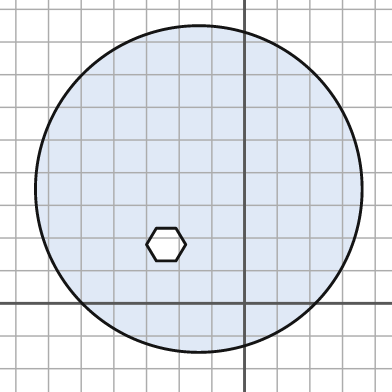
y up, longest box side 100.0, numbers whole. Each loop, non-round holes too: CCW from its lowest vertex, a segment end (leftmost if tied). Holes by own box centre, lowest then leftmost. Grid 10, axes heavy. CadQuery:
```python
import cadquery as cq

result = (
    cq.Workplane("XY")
    .moveTo(-14.0, 35.0)
    .circle(50.0)
    .moveTo(-27.0, 13.0)
    .lineTo(-21.0, 13.0)
    .lineTo(-18.0, 18.0)
    .lineTo(-21.0, 23.0)
    .lineTo(-27.0, 23.0)
    .lineTo(-30.0, 18.0)
    .close()
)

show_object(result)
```